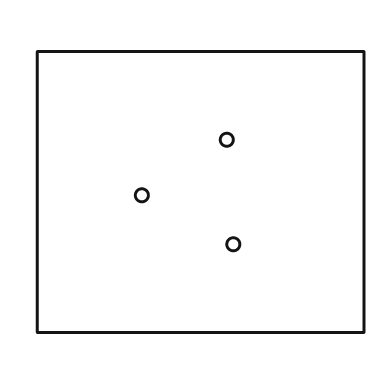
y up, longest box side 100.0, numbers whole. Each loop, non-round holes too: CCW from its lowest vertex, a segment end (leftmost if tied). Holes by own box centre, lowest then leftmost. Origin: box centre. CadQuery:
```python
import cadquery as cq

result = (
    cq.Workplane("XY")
    .moveTo(-50.0, -43.0)
    .lineTo(50.0, -43.0)
    .lineTo(50.0, 43.0)
    .lineTo(-50.0, 43.0)
    .close()
    .moveTo(10.0, -16.0)
    .circle(2.0)
    .moveTo(-18.0, -1.0)
    .circle(2.0)
    .moveTo(8.0, 16.0)
    .circle(2.0)
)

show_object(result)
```